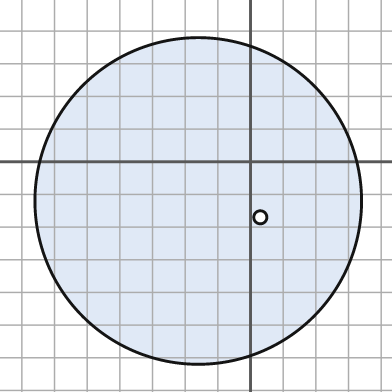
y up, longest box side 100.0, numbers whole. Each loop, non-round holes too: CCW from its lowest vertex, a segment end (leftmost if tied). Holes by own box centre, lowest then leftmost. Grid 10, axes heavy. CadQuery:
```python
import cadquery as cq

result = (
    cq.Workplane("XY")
    .moveTo(-16.0, -12.0)
    .circle(50.0)
    .moveTo(3.0, -17.0)
    .circle(2.0)
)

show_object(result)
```